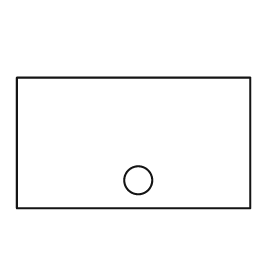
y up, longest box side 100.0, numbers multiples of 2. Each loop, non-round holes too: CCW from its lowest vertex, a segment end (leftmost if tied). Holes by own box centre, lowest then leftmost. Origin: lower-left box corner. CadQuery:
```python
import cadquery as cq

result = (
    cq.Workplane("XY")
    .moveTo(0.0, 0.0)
    .lineTo(100.0, 0.0)
    .lineTo(100.0, 56.0)
    .lineTo(0.0, 56.0)
    .close()
    .moveTo(52.0, 12.0)
    .circle(6.0)
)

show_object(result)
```